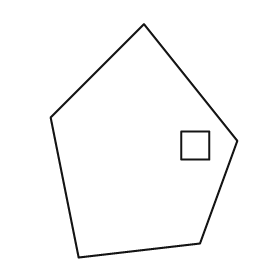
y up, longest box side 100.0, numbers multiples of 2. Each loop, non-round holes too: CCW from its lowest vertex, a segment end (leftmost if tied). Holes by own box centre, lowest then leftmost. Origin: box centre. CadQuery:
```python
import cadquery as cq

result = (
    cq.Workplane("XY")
    .moveTo(-28.0, -50.0)
    .lineTo(24.0, -44.0)
    .lineTo(40.0, 0.0)
    .lineTo(0.0, 50.0)
    .lineTo(-40.0, 10.0)
    .close()
    .moveTo(16.0, -8.0)
    .lineTo(28.0, -8.0)
    .lineTo(28.0, 4.0)
    .lineTo(16.0, 4.0)
    .close()
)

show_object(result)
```